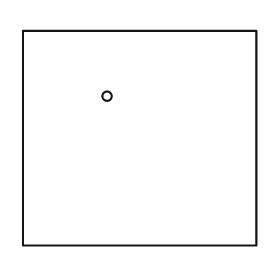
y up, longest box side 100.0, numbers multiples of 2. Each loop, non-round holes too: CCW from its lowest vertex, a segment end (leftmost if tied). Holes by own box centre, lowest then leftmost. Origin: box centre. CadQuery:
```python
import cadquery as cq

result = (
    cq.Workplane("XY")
    .moveTo(-50.0, -46.0)
    .lineTo(50.0, -46.0)
    .lineTo(50.0, 46.0)
    .lineTo(-50.0, 46.0)
    .close()
    .moveTo(-14.0, 18.0)
    .circle(2.0)
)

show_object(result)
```